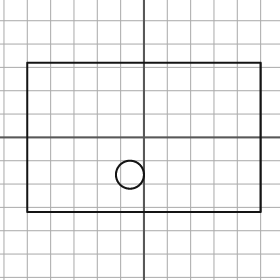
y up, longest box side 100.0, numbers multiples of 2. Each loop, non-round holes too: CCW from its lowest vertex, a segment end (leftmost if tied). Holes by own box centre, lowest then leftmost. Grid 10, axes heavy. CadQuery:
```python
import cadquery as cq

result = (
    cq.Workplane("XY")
    .moveTo(-50.0, -32.0)
    .lineTo(50.0, -32.0)
    .lineTo(50.0, 32.0)
    .lineTo(-50.0, 32.0)
    .close()
    .moveTo(-6.0, -16.0)
    .circle(6.0)
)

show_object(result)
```